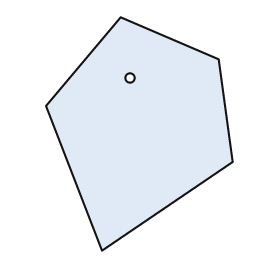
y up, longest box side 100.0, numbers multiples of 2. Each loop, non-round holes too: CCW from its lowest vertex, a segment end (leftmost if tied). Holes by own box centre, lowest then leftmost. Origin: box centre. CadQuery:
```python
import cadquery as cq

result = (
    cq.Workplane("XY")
    .moveTo(-16.0, -50.0)
    .lineTo(40.0, -12.0)
    .lineTo(34.0, 32.0)
    .lineTo(-8.0, 50.0)
    .lineTo(-40.0, 12.0)
    .close()
    .moveTo(-4.0, 24.0)
    .circle(2.0)
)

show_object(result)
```